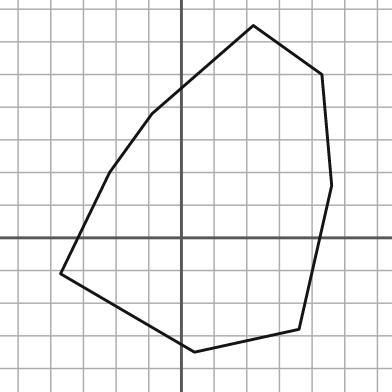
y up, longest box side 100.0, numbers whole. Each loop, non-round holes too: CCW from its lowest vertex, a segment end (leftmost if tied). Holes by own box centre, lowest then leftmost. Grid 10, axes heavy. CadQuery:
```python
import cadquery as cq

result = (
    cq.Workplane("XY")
    .moveTo(4.0, -35.0)
    .lineTo(36.0, -28.0)
    .lineTo(46.0, 16.0)
    .lineTo(43.0, 50.0)
    .lineTo(22.0, 65.0)
    .lineTo(-9.0, 38.0)
    .lineTo(-22.0, 20.0)
    .lineTo(-37.0, -11.0)
    .close()
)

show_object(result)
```